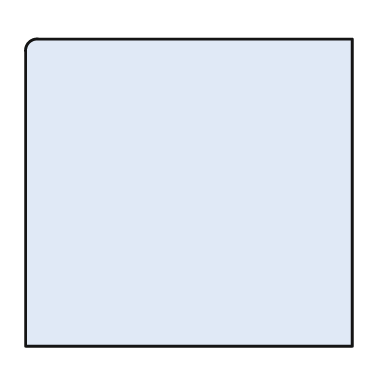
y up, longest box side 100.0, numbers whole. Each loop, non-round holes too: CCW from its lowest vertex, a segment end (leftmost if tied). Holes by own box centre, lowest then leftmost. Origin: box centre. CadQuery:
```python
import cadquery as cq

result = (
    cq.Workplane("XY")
    .moveTo(-50.0, -47.0)
    .lineTo(50.0, -47.0)
    .lineTo(50.0, 47.0)
    .lineTo(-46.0, 47.0)
    .threePointArc((-49.0, 46.0), (-50.0, 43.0))
    .close()
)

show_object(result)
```